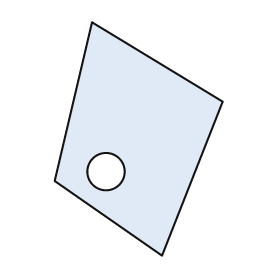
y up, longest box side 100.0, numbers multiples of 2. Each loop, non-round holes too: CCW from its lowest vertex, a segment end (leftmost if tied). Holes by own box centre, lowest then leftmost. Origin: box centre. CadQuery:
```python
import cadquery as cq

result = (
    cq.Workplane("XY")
    .moveTo(10.0, -50.0)
    .lineTo(36.0, 16.0)
    .lineTo(-20.0, 50.0)
    .lineTo(-36.0, -18.0)
    .close()
    .moveTo(-14.0, -14.0)
    .circle(8.0)
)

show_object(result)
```